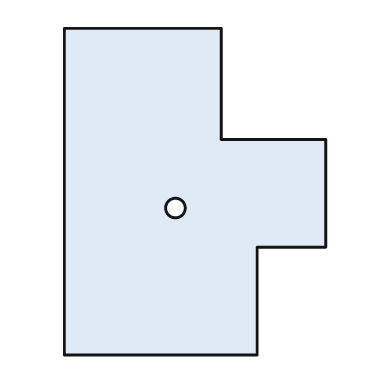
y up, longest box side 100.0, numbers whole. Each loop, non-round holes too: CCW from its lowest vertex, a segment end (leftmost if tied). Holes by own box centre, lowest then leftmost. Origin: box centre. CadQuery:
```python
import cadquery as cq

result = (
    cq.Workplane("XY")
    .moveTo(-40.0, -50.0)
    .lineTo(19.0, -50.0)
    .lineTo(19.0, -17.0)
    .lineTo(40.0, -17.0)
    .lineTo(40.0, 16.0)
    .lineTo(8.0, 16.0)
    .lineTo(8.0, 50.0)
    .lineTo(-40.0, 50.0)
    .close()
    .moveTo(-6.0, -5.0)
    .circle(3.0)
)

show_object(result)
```